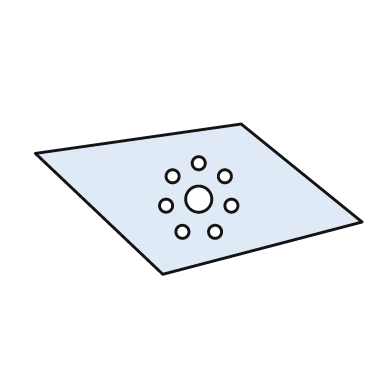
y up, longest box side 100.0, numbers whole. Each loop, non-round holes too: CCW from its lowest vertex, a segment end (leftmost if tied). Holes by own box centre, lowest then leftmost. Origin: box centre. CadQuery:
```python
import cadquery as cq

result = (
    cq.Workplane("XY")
    .moveTo(-11.0, -23.0)
    .lineTo(50.0, -7.0)
    .lineTo(13.0, 23.0)
    .lineTo(-50.0, 14.0)
    .close()
    .moveTo(-5.0, -10.0)
    .circle(2.0)
    .moveTo(5.0, -10.0)
    .circle(2.0)
    .moveTo(-10.0, -2.0)
    .circle(2.0)
    .moveTo(10.0, -2.0)
    .circle(2.0)
    .moveTo(0.0, 0.0)
    .circle(4.0)
    .moveTo(-8.0, 7.0)
    .circle(2.0)
    .moveTo(8.0, 7.0)
    .circle(2.0)
    .moveTo(0.0, 11.0)
    .circle(2.0)
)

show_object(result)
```